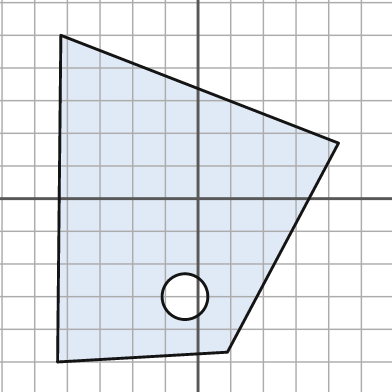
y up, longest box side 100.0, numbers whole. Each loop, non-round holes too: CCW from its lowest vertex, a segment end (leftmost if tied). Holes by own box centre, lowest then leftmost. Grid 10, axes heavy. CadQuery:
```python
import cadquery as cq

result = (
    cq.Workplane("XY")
    .moveTo(-43.0, -50.0)
    .lineTo(9.0, -47.0)
    .lineTo(43.0, 17.0)
    .lineTo(-42.0, 50.0)
    .close()
    .moveTo(-4.0, -30.0)
    .circle(7.0)
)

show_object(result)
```